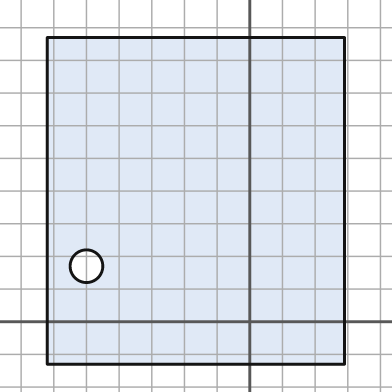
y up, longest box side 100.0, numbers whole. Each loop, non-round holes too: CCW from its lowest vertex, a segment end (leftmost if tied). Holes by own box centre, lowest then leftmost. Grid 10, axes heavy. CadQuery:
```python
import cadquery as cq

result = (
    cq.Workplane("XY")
    .moveTo(-62.0, -13.0)
    .lineTo(29.0, -13.0)
    .lineTo(29.0, 87.0)
    .lineTo(-62.0, 87.0)
    .close()
    .moveTo(-50.0, 17.0)
    .circle(5.0)
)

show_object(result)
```